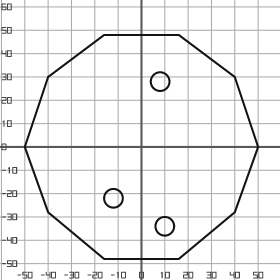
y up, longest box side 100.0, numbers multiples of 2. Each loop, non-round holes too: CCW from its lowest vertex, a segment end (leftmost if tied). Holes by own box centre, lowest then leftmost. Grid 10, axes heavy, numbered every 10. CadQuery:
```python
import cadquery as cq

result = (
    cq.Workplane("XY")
    .moveTo(-16.0, -48.0)
    .lineTo(16.0, -48.0)
    .lineTo(40.0, -28.0)
    .lineTo(50.0, 0.0)
    .lineTo(40.0, 30.0)
    .lineTo(16.0, 48.0)
    .lineTo(-16.0, 48.0)
    .lineTo(-40.0, 30.0)
    .lineTo(-50.0, 0.0)
    .lineTo(-40.0, -28.0)
    .close()
    .moveTo(10.0, -34.0)
    .circle(4.0)
    .moveTo(-12.0, -22.0)
    .circle(4.0)
    .moveTo(8.0, 28.0)
    .circle(4.0)
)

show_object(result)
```